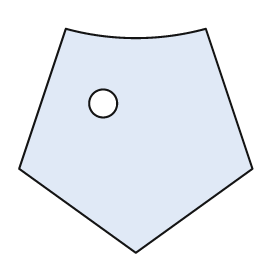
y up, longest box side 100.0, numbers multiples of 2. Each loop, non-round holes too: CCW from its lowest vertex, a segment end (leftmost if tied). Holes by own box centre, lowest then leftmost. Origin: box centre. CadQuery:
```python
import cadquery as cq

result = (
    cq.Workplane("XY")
    .moveTo(0.0, -48.0)
    .lineTo(50.0, -12.0)
    .lineTo(30.0, 48.0)
    .threePointArc((0.0, 44.0), (-30.0, 48.0))
    .lineTo(-50.0, -12.0)
    .close()
    .moveTo(-14.0, 16.0)
    .circle(6.0)
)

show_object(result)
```